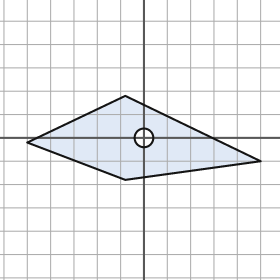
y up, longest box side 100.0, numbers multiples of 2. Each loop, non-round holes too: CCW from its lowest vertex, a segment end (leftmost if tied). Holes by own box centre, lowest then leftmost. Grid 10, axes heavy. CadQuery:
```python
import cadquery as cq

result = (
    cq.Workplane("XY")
    .moveTo(-8.0, -18.0)
    .lineTo(50.0, -10.0)
    .lineTo(-8.0, 18.0)
    .lineTo(-50.0, -2.0)
    .close()
    .moveTo(0.0, 0.0)
    .circle(4.0)
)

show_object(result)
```